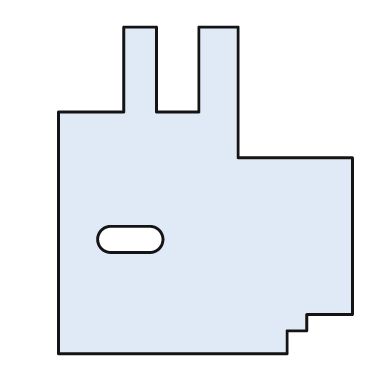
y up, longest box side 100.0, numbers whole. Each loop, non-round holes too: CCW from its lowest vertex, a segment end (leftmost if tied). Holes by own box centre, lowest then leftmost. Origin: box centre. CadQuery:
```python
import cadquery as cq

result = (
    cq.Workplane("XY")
    .moveTo(-45.0, -50.0)
    .lineTo(25.0, -50.0)
    .lineTo(25.0, -43.0)
    .lineTo(31.0, -43.0)
    .lineTo(31.0, -38.0)
    .lineTo(45.0, -38.0)
    .lineTo(45.0, 10.0)
    .lineTo(10.0, 10.0)
    .lineTo(10.0, 50.0)
    .lineTo(-2.0, 50.0)
    .lineTo(-2.0, 24.0)
    .lineTo(-15.0, 24.0)
    .lineTo(-15.0, 50.0)
    .lineTo(-25.0, 50.0)
    .lineTo(-25.0, 24.0)
    .lineTo(-45.0, 24.0)
    .close()
    .moveTo(-29.0, -19.0)
    .lineTo(-17.0, -19.0)
    .threePointArc((-13.0, -15.0), (-17.0, -11.0))
    .lineTo(-29.0, -11.0)
    .threePointArc((-33.0, -15.0), (-29.0, -19.0))
    .close()
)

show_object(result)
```